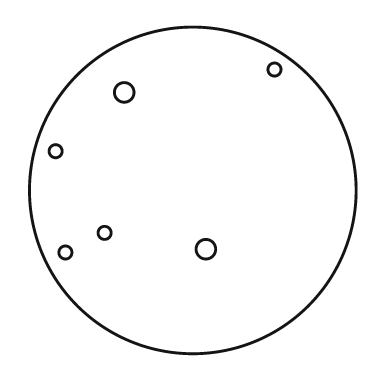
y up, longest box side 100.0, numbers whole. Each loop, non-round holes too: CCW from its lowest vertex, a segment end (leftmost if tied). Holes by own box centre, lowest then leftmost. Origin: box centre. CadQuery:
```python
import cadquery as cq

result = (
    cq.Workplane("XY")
    .moveTo(0.0, 0.0)
    .circle(50.0)
    .moveTo(-39.0, -19.0)
    .circle(2.0)
    .moveTo(4.0, -18.0)
    .circle(3.0)
    .moveTo(-27.0, -13.0)
    .circle(2.0)
    .moveTo(-42.0, 12.0)
    .circle(2.0)
    .moveTo(-21.0, 30.0)
    .circle(3.0)
    .moveTo(25.0, 37.0)
    .circle(2.0)
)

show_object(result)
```